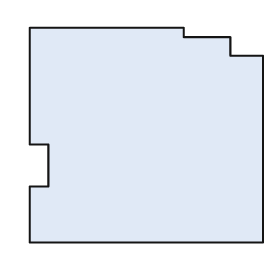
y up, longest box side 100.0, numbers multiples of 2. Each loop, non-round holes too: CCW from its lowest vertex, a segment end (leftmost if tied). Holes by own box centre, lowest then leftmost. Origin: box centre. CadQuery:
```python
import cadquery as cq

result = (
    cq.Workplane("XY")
    .moveTo(-50.0, -46.0)
    .lineTo(50.0, -46.0)
    .lineTo(50.0, 34.0)
    .lineTo(36.0, 34.0)
    .lineTo(36.0, 42.0)
    .lineTo(16.0, 42.0)
    .lineTo(16.0, 46.0)
    .lineTo(-50.0, 46.0)
    .lineTo(-50.0, -4.0)
    .lineTo(-42.0, -4.0)
    .lineTo(-42.0, -22.0)
    .lineTo(-50.0, -22.0)
    .close()
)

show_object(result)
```